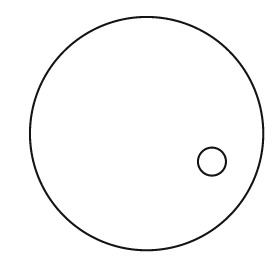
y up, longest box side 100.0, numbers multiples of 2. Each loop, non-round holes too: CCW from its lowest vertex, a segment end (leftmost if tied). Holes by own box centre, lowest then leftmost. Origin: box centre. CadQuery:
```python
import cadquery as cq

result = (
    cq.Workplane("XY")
    .moveTo(0.0, 0.0)
    .circle(50.0)
    .moveTo(28.0, -12.0)
    .circle(6.0)
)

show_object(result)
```